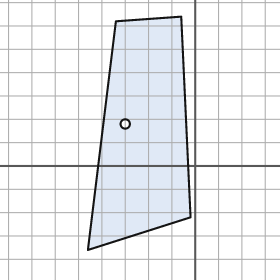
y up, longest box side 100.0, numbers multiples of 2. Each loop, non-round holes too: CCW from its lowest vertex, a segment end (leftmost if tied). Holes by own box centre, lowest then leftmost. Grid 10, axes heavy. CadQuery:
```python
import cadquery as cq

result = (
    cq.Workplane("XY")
    .moveTo(-46.0, -36.0)
    .lineTo(-2.0, -22.0)
    .lineTo(-6.0, 64.0)
    .lineTo(-34.0, 62.0)
    .close()
    .moveTo(-30.0, 18.0)
    .circle(2.0)
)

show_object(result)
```